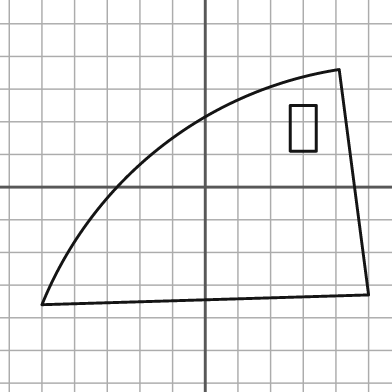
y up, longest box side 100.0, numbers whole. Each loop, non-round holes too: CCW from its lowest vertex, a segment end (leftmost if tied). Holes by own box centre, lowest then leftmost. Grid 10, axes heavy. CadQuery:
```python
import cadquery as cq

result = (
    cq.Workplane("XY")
    .moveTo(-50.0, -36.0)
    .lineTo(50.0, -33.0)
    .lineTo(41.0, 36.0)
    .threePointArc((-14.0, 12.0), (-50.0, -36.0))
    .close()
    .moveTo(26.0, 11.0)
    .lineTo(34.0, 11.0)
    .lineTo(34.0, 25.0)
    .lineTo(26.0, 25.0)
    .close()
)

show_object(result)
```